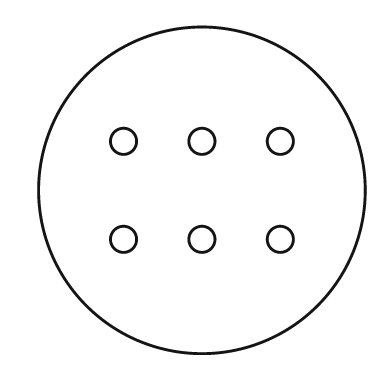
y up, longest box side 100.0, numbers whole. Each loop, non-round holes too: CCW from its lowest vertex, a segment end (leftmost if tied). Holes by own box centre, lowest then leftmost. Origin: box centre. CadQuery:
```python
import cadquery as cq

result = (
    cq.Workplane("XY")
    .moveTo(0.0, 0.0)
    .circle(50.0)
    .moveTo(-24.0, -15.0)
    .circle(4.0)
    .moveTo(0.0, -15.0)
    .circle(4.0)
    .moveTo(24.0, -15.0)
    .circle(4.0)
    .moveTo(-24.0, 15.0)
    .circle(4.0)
    .moveTo(0.0, 15.0)
    .circle(4.0)
    .moveTo(24.0, 15.0)
    .circle(4.0)
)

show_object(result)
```